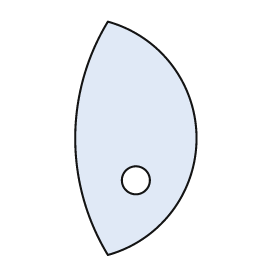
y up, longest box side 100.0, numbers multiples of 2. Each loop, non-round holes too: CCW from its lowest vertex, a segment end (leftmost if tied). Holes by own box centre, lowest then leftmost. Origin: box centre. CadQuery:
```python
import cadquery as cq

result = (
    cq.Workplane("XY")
    .moveTo(-12.0, -50.0)
    .threePointArc((26.0, 0.0), (-12.0, 50.0))
    .threePointArc((-26.0, 0.0), (-12.0, -50.0))
    .close()
    .moveTo(0.0, -18.0)
    .circle(6.0)
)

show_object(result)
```